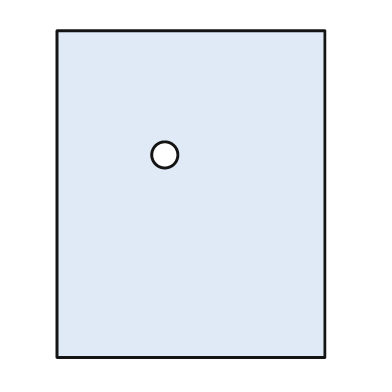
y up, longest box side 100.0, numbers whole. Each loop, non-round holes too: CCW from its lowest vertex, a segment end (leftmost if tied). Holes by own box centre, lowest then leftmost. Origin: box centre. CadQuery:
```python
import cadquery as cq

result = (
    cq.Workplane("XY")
    .moveTo(-41.0, -50.0)
    .lineTo(41.0, -50.0)
    .lineTo(41.0, 50.0)
    .lineTo(-41.0, 50.0)
    .close()
    .moveTo(-8.0, 12.0)
    .circle(4.0)
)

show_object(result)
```